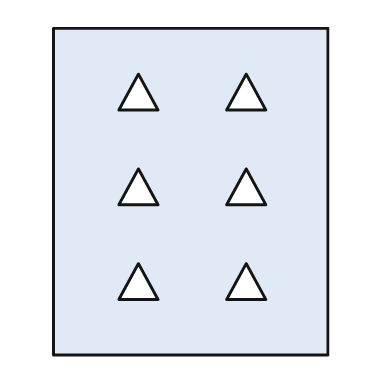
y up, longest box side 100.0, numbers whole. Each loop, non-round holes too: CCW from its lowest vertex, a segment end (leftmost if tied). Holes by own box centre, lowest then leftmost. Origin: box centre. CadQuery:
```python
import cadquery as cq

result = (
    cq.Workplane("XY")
    .moveTo(-42.0, -50.0)
    .lineTo(42.0, -50.0)
    .lineTo(42.0, 50.0)
    .lineTo(-42.0, 50.0)
    .close()
    .moveTo(-22.0, -33.0)
    .lineTo(-10.0, -33.0)
    .lineTo(-16.0, -22.0)
    .close()
    .moveTo(11.0, -33.0)
    .lineTo(23.0, -33.0)
    .lineTo(17.0, -22.0)
    .close()
    .moveTo(-22.0, -4.0)
    .lineTo(-10.0, -4.0)
    .lineTo(-16.0, 7.0)
    .close()
    .moveTo(11.0, -4.0)
    .lineTo(23.0, -4.0)
    .lineTo(17.0, 7.0)
    .close()
    .moveTo(-22.0, 25.0)
    .lineTo(-10.0, 25.0)
    .lineTo(-16.0, 36.0)
    .close()
    .moveTo(11.0, 25.0)
    .lineTo(23.0, 25.0)
    .lineTo(17.0, 36.0)
    .close()
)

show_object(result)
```